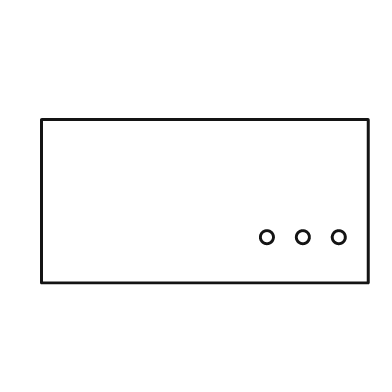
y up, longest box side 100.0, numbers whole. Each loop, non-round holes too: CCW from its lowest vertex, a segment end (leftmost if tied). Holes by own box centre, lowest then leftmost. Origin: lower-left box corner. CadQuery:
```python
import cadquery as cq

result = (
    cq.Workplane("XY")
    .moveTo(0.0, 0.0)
    .lineTo(100.0, 0.0)
    .lineTo(100.0, 50.0)
    .lineTo(0.0, 50.0)
    .close()
    .moveTo(69.0, 14.0)
    .circle(2.0)
    .moveTo(80.0, 14.0)
    .circle(2.0)
    .moveTo(91.0, 14.0)
    .circle(2.0)
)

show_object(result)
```